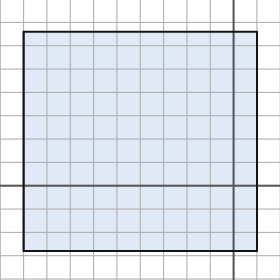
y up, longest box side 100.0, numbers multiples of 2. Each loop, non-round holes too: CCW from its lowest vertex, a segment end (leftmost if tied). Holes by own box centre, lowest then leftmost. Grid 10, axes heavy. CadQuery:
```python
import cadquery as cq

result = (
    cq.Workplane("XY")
    .moveTo(-90.0, -28.0)
    .lineTo(10.0, -28.0)
    .lineTo(10.0, 66.0)
    .lineTo(-90.0, 66.0)
    .close()
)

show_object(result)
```